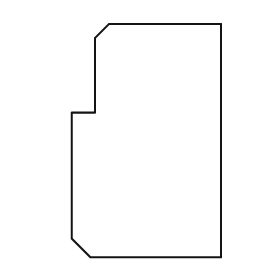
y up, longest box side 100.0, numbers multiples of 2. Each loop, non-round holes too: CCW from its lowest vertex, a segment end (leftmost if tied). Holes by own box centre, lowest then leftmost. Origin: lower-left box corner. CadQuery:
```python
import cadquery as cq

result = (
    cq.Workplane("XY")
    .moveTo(8.0, 0.0)
    .lineTo(64.0, 0.0)
    .lineTo(64.0, 100.0)
    .lineTo(16.0, 100.0)
    .lineTo(10.0, 94.0)
    .lineTo(10.0, 62.0)
    .lineTo(0.0, 62.0)
    .lineTo(0.0, 8.0)
    .close()
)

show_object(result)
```